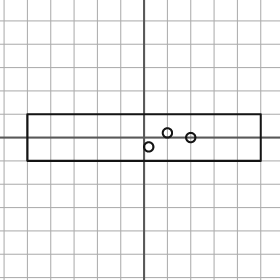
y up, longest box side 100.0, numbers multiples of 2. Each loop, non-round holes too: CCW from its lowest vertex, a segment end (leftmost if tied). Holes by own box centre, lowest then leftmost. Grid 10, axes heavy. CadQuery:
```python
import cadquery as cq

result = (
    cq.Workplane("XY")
    .moveTo(-50.0, -10.0)
    .lineTo(50.0, -10.0)
    .lineTo(50.0, 10.0)
    .lineTo(-50.0, 10.0)
    .close()
    .moveTo(2.0, -4.0)
    .circle(2.0)
    .moveTo(20.0, 0.0)
    .circle(2.0)
    .moveTo(10.0, 2.0)
    .circle(2.0)
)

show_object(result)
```